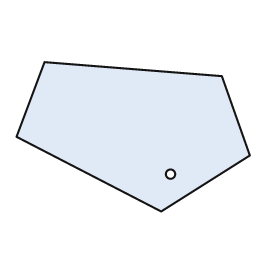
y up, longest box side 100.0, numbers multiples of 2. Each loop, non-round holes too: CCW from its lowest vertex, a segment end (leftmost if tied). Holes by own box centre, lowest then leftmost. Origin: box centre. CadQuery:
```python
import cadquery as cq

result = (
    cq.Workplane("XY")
    .moveTo(12.0, -32.0)
    .lineTo(50.0, -8.0)
    .lineTo(38.0, 26.0)
    .lineTo(-38.0, 32.0)
    .lineTo(-50.0, 0.0)
    .close()
    .moveTo(16.0, -16.0)
    .circle(2.0)
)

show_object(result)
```